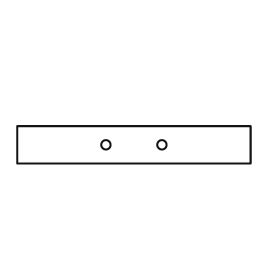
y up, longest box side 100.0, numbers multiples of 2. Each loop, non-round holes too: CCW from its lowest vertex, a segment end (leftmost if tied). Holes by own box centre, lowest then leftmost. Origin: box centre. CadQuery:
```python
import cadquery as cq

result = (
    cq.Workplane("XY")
    .moveTo(-50.0, -8.0)
    .lineTo(50.0, -8.0)
    .lineTo(50.0, 8.0)
    .lineTo(-50.0, 8.0)
    .close()
    .moveTo(-12.0, 0.0)
    .circle(2.0)
    .moveTo(12.0, 0.0)
    .circle(2.0)
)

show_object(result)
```